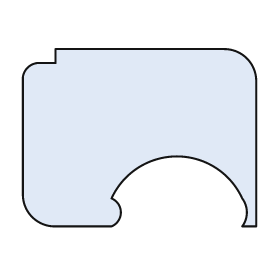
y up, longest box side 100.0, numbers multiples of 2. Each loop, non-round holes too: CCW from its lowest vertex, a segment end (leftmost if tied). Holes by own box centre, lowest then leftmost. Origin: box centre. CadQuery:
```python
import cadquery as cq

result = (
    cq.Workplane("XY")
    .moveTo(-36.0, -38.0)
    .lineTo(-12.0, -38.0)
    .threePointArc((-8.0, -32.0), (-12.0, -26.0))
    .threePointArc((16.0, -8.0), (44.0, -26.0))
    .threePointArc((46.0, -32.0), (44.0, -38.0))
    .lineTo(50.0, -38.0)
    .lineTo(50.0, 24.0)
    .threePointArc((46.0, 34.0), (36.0, 38.0))
    .lineTo(-36.0, 38.0)
    .lineTo(-36.0, 32.0)
    .lineTo(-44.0, 32.0)
    .threePointArc((-48.0, 30.0), (-50.0, 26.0))
    .lineTo(-50.0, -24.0)
    .threePointArc((-46.0, -34.0), (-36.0, -38.0))
    .close()
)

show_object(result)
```